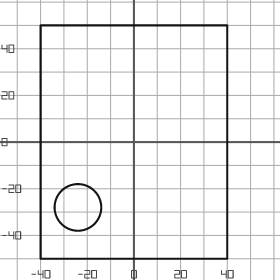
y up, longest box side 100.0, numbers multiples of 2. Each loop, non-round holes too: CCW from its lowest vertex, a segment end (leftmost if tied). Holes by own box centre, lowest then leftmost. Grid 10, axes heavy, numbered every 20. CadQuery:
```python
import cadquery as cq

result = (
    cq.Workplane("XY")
    .moveTo(-40.0, -50.0)
    .lineTo(40.0, -50.0)
    .lineTo(40.0, 50.0)
    .lineTo(-40.0, 50.0)
    .close()
    .moveTo(-24.0, -28.0)
    .circle(10.0)
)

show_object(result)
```